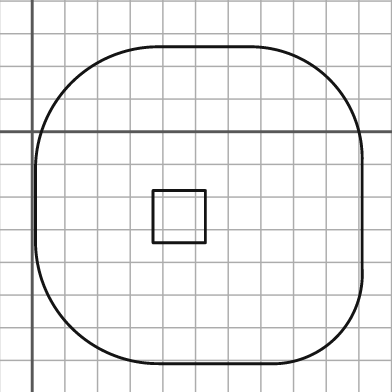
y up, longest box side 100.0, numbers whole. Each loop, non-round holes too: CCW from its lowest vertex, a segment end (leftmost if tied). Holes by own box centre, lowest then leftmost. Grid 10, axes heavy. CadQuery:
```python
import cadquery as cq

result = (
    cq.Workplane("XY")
    .moveTo(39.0, -71.0)
    .lineTo(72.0, -71.0)
    .threePointArc((93.0, -63.0), (101.0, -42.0))
    .lineTo(101.0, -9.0)
    .threePointArc((91.0, 16.0), (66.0, 26.0))
    .lineTo(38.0, 26.0)
    .threePointArc((12.0, 15.0), (1.0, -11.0))
    .lineTo(1.0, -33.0)
    .threePointArc((12.0, -60.0), (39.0, -71.0))
    .close()
    .moveTo(37.0, -34.0)
    .lineTo(53.0, -34.0)
    .lineTo(53.0, -18.0)
    .lineTo(37.0, -18.0)
    .close()
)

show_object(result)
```